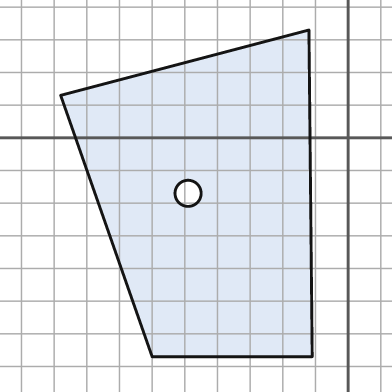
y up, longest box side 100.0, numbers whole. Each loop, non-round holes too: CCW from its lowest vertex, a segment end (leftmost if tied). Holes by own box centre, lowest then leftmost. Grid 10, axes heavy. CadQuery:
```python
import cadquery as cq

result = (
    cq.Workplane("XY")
    .moveTo(-60.0, -67.0)
    .lineTo(-11.0, -67.0)
    .lineTo(-12.0, 33.0)
    .lineTo(-88.0, 13.0)
    .close()
    .moveTo(-49.0, -17.0)
    .circle(4.0)
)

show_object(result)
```